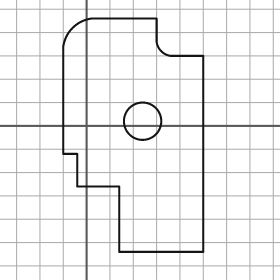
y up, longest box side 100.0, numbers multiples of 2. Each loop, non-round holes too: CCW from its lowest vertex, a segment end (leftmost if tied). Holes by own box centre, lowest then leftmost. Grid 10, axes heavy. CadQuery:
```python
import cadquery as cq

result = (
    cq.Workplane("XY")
    .moveTo(14.0, -54.0)
    .lineTo(50.0, -54.0)
    .lineTo(50.0, 30.0)
    .lineTo(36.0, 30.0)
    .threePointArc((32.0, 32.0), (30.0, 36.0))
    .lineTo(30.0, 46.0)
    .lineTo(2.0, 46.0)
    .threePointArc((-6.0, 42.0), (-10.0, 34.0))
    .lineTo(-10.0, -12.0)
    .lineTo(-4.0, -12.0)
    .lineTo(-4.0, -26.0)
    .lineTo(14.0, -26.0)
    .close()
    .moveTo(24.0, 2.0)
    .circle(8.0)
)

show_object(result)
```